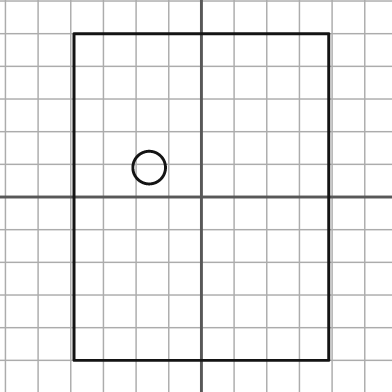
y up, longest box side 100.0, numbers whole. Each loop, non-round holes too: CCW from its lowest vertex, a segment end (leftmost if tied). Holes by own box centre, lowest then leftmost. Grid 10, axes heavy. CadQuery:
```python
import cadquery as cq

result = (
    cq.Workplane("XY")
    .moveTo(-39.0, -50.0)
    .lineTo(39.0, -50.0)
    .lineTo(39.0, 50.0)
    .lineTo(-39.0, 50.0)
    .close()
    .moveTo(-16.0, 9.0)
    .circle(5.0)
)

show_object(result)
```